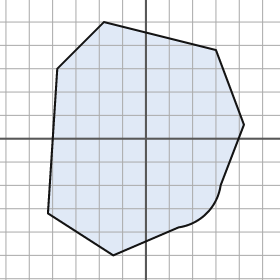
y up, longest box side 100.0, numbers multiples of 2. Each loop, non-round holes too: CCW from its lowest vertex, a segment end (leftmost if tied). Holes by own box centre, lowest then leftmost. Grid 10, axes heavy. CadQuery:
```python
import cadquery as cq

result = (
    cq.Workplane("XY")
    .moveTo(-14.0, -50.0)
    .lineTo(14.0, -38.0)
    .threePointArc((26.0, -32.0), (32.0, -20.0))
    .lineTo(42.0, 6.0)
    .lineTo(30.0, 38.0)
    .lineTo(-18.0, 50.0)
    .lineTo(-38.0, 30.0)
    .lineTo(-42.0, -32.0)
    .close()
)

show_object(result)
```